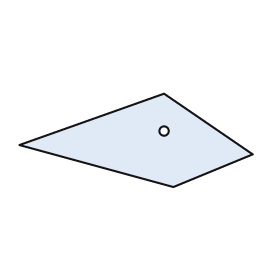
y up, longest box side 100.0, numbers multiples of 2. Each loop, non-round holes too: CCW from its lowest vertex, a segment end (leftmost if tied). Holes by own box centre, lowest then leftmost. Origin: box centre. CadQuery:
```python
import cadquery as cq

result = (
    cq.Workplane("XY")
    .moveTo(16.0, -20.0)
    .lineTo(50.0, -6.0)
    .lineTo(12.0, 20.0)
    .lineTo(-50.0, -2.0)
    .close()
    .moveTo(12.0, 4.0)
    .circle(2.0)
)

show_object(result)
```